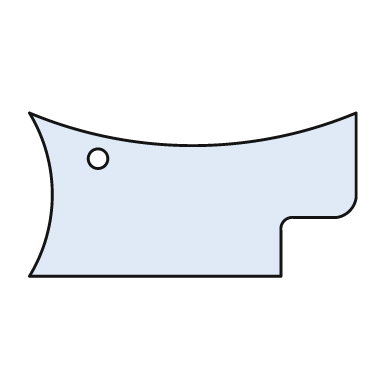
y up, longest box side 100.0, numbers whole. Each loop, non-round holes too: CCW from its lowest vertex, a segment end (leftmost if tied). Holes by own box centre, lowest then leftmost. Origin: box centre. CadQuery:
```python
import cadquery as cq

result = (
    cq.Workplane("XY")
    .moveTo(-50.0, -25.0)
    .lineTo(27.0, -25.0)
    .lineTo(27.0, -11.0)
    .threePointArc((28.0, -8.0), (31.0, -7.0))
    .lineTo(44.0, -7.0)
    .threePointArc((48.0, -5.0), (50.0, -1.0))
    .lineTo(50.0, 25.0)
    .threePointArc((0.0, 15.0), (-50.0, 25.0))
    .threePointArc((-43.0, 0.0), (-50.0, -25.0))
    .close()
    .moveTo(-29.0, 11.0)
    .circle(3.0)
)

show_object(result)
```